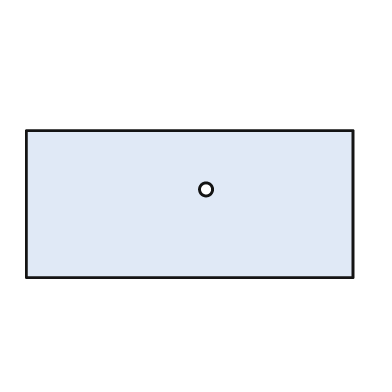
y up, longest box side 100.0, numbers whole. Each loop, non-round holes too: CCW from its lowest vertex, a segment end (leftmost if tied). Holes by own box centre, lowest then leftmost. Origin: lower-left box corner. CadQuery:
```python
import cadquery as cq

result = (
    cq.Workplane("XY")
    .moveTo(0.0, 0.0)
    .lineTo(100.0, 0.0)
    .lineTo(100.0, 45.0)
    .lineTo(0.0, 45.0)
    .close()
    .moveTo(55.0, 27.0)
    .circle(2.0)
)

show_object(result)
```